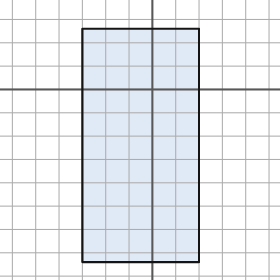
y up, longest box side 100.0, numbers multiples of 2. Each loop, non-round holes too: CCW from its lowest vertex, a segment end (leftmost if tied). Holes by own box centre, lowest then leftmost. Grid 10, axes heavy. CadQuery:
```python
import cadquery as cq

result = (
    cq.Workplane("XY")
    .moveTo(-30.0, -74.0)
    .lineTo(20.0, -74.0)
    .lineTo(20.0, 26.0)
    .lineTo(-30.0, 26.0)
    .close()
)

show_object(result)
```